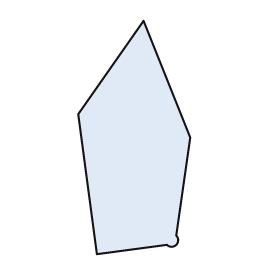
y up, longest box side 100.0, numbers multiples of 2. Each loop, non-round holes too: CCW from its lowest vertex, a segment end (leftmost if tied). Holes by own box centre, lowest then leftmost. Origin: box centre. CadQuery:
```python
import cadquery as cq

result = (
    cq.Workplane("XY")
    .moveTo(-16.0, -50.0)
    .lineTo(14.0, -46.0)
    .threePointArc((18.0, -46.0), (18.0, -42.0))
    .lineTo(24.0, 0.0)
    .lineTo(4.0, 50.0)
    .lineTo(-24.0, 10.0)
    .close()
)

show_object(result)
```